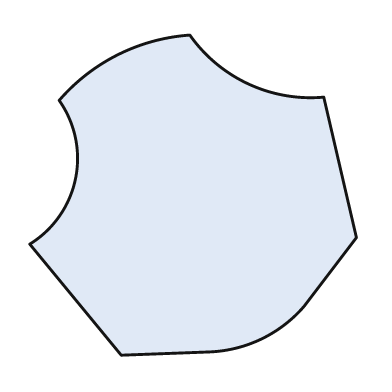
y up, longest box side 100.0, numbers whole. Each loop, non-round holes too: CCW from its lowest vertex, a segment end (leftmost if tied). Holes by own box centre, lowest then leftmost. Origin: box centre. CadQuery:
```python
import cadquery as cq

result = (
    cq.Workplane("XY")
    .moveTo(-22.0, -49.0)
    .lineTo(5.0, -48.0)
    .threePointArc((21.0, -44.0), (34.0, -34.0))
    .lineTo(50.0, -13.0)
    .lineTo(40.0, 30.0)
    .threePointArc((17.0, 34.0), (-1.0, 49.0))
    .threePointArc((-23.0, 43.0), (-41.0, 29.0))
    .threePointArc((-36.0, 5.0), (-50.0, -15.0))
    .close()
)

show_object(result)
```